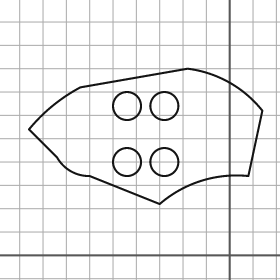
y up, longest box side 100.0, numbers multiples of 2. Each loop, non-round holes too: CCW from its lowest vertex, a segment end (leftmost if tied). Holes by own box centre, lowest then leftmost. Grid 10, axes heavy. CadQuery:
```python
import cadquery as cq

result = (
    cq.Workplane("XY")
    .moveTo(-30.0, 22.0)
    .threePointArc((-12.0, 32.0), (8.0, 34.0))
    .lineTo(14.0, 62.0)
    .threePointArc((0.0, 74.0), (-18.0, 80.0))
    .lineTo(-64.0, 72.0)
    .threePointArc((-76.0, 64.0), (-86.0, 54.0))
    .lineTo(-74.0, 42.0)
    .threePointArc((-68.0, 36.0), (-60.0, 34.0))
    .close()
    .moveTo(-44.0, 40.0)
    .circle(6.0)
    .moveTo(-28.0, 40.0)
    .circle(6.0)
    .moveTo(-44.0, 64.0)
    .circle(6.0)
    .moveTo(-28.0, 64.0)
    .circle(6.0)
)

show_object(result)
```